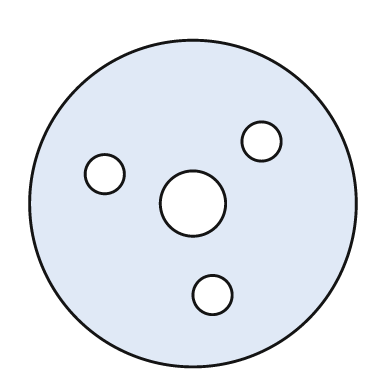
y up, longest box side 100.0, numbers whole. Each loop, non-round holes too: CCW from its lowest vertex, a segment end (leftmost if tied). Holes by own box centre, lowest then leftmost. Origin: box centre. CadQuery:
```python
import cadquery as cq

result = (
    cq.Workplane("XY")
    .moveTo(0.0, 0.0)
    .circle(50.0)
    .moveTo(6.0, -28.0)
    .circle(6.0)
    .moveTo(0.0, 0.0)
    .circle(10.0)
    .moveTo(-27.0, 9.0)
    .circle(6.0)
    .moveTo(21.0, 19.0)
    .circle(6.0)
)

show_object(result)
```